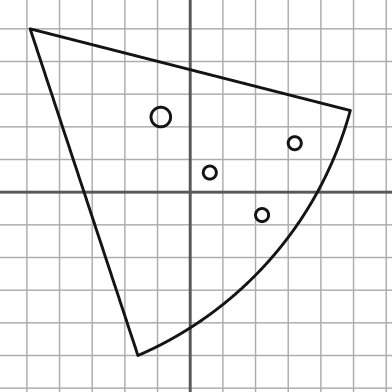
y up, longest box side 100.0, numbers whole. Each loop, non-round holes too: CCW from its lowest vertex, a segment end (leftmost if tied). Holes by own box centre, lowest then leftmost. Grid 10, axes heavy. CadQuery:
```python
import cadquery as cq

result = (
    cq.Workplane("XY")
    .moveTo(-16.0, -50.0)
    .threePointArc((25.0, -20.0), (49.0, 25.0))
    .lineTo(-49.0, 50.0)
    .close()
    .moveTo(22.0, -7.0)
    .circle(2.0)
    .moveTo(6.0, 6.0)
    .circle(2.0)
    .moveTo(32.0, 15.0)
    .circle(2.0)
    .moveTo(-9.0, 23.0)
    .circle(3.0)
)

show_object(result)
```